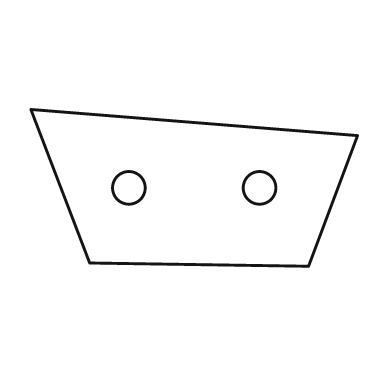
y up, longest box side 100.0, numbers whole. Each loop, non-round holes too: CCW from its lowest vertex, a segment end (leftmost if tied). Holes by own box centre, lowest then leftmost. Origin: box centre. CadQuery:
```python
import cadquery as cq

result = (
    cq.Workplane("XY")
    .moveTo(35.0, -24.0)
    .lineTo(50.0, 16.0)
    .lineTo(-50.0, 24.0)
    .lineTo(-32.0, -23.0)
    .close()
    .moveTo(-20.0, 0.0)
    .circle(5.0)
    .moveTo(20.0, 0.0)
    .circle(5.0)
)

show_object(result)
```